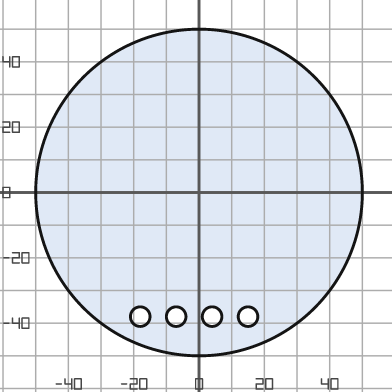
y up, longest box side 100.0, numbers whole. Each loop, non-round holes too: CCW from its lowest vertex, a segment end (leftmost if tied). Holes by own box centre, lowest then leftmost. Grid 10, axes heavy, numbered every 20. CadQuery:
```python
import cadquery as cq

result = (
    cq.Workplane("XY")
    .moveTo(0.0, 0.0)
    .circle(50.0)
    .moveTo(-18.0, -38.0)
    .circle(3.0)
    .moveTo(-7.0, -38.0)
    .circle(3.0)
    .moveTo(4.0, -38.0)
    .circle(3.0)
    .moveTo(15.0, -38.0)
    .circle(3.0)
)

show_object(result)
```